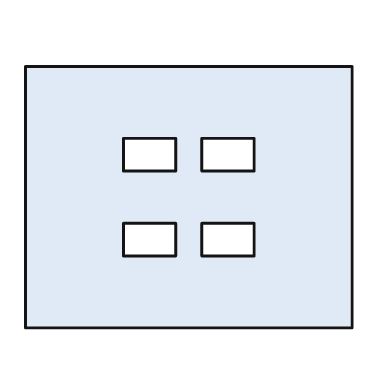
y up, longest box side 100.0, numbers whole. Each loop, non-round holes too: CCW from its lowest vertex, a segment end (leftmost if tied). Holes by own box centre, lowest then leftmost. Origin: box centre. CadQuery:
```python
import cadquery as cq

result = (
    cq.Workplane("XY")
    .moveTo(-50.0, -40.0)
    .lineTo(50.0, -40.0)
    .lineTo(50.0, 40.0)
    .lineTo(-50.0, 40.0)
    .close()
    .moveTo(-20.0, -18.0)
    .lineTo(-4.0, -18.0)
    .lineTo(-4.0, -8.0)
    .lineTo(-20.0, -8.0)
    .close()
    .moveTo(4.0, -18.0)
    .lineTo(20.0, -18.0)
    .lineTo(20.0, -8.0)
    .lineTo(4.0, -8.0)
    .close()
    .moveTo(-20.0, 8.0)
    .lineTo(-4.0, 8.0)
    .lineTo(-4.0, 18.0)
    .lineTo(-20.0, 18.0)
    .close()
    .moveTo(4.0, 8.0)
    .lineTo(20.0, 8.0)
    .lineTo(20.0, 18.0)
    .lineTo(4.0, 18.0)
    .close()
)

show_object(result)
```